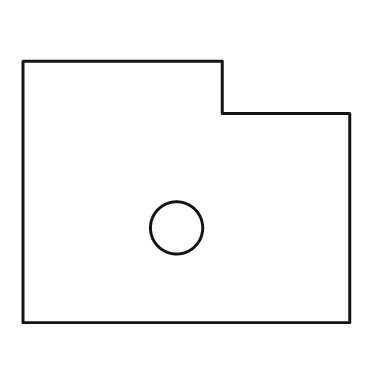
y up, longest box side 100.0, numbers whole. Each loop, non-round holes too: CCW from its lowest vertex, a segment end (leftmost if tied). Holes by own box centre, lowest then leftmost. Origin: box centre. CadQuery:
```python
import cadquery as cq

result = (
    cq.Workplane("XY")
    .moveTo(-50.0, -40.0)
    .lineTo(50.0, -40.0)
    .lineTo(50.0, 24.0)
    .lineTo(11.0, 24.0)
    .lineTo(11.0, 40.0)
    .lineTo(-50.0, 40.0)
    .close()
    .moveTo(-3.0, -11.0)
    .circle(8.0)
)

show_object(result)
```